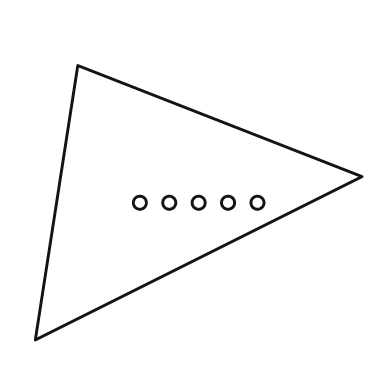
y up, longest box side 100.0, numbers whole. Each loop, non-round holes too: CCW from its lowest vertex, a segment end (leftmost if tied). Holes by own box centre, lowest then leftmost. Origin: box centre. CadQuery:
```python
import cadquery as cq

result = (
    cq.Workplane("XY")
    .moveTo(-50.0, -42.0)
    .lineTo(50.0, 8.0)
    .lineTo(-37.0, 42.0)
    .close()
    .moveTo(-18.0, 0.0)
    .circle(2.0)
    .moveTo(-9.0, 0.0)
    .circle(2.0)
    .moveTo(0.0, 0.0)
    .circle(2.0)
    .moveTo(9.0, 0.0)
    .circle(2.0)
    .moveTo(18.0, 0.0)
    .circle(2.0)
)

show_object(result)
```